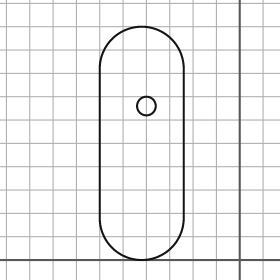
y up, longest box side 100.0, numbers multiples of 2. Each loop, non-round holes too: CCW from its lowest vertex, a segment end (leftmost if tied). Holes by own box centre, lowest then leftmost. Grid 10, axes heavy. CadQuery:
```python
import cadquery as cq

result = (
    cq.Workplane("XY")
    .moveTo(-60.0, 18.0)
    .threePointArc((-42.0, 0.0), (-24.0, 18.0))
    .lineTo(-24.0, 82.0)
    .threePointArc((-42.0, 100.0), (-60.0, 82.0))
    .close()
    .moveTo(-40.0, 66.0)
    .circle(4.0)
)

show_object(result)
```